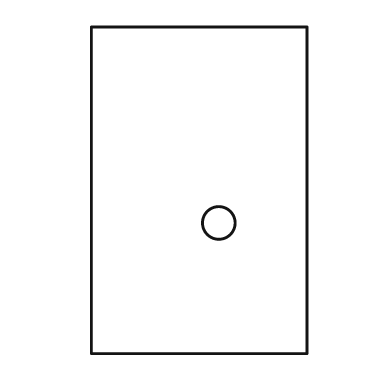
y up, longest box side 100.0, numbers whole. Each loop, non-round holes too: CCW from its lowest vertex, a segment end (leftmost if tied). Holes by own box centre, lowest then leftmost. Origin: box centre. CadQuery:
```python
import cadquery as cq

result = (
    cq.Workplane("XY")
    .moveTo(-33.0, -50.0)
    .lineTo(33.0, -50.0)
    .lineTo(33.0, 50.0)
    .lineTo(-33.0, 50.0)
    .close()
    .moveTo(6.0, -10.0)
    .circle(5.0)
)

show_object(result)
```